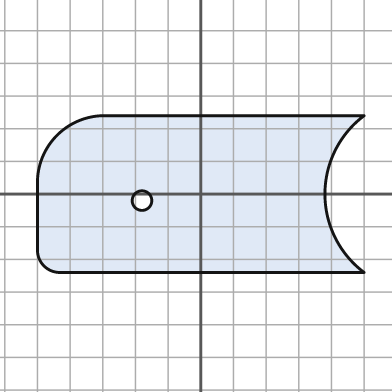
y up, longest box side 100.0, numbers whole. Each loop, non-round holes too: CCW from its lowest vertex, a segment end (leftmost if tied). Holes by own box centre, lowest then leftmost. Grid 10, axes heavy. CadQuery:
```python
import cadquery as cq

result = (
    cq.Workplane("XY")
    .moveTo(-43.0, -24.0)
    .lineTo(50.0, -24.0)
    .threePointArc((38.0, 0.0), (50.0, 24.0))
    .lineTo(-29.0, 24.0)
    .threePointArc((-44.0, 18.0), (-50.0, 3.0))
    .lineTo(-50.0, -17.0)
    .threePointArc((-48.0, -22.0), (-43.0, -24.0))
    .close()
    .moveTo(-18.0, -2.0)
    .circle(3.0)
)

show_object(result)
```